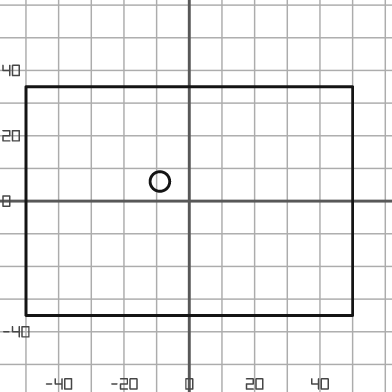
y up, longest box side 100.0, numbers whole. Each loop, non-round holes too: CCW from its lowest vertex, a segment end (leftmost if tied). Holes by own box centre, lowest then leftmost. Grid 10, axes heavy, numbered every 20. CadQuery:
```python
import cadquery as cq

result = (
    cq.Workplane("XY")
    .moveTo(-50.0, -35.0)
    .lineTo(50.0, -35.0)
    .lineTo(50.0, 35.0)
    .lineTo(-50.0, 35.0)
    .close()
    .moveTo(-9.0, 6.0)
    .circle(3.0)
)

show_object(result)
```